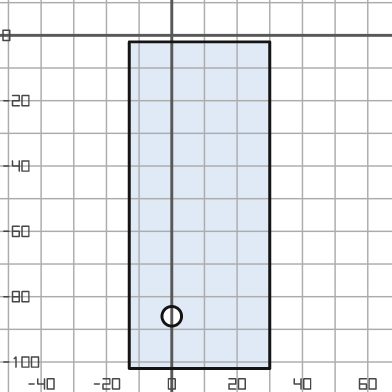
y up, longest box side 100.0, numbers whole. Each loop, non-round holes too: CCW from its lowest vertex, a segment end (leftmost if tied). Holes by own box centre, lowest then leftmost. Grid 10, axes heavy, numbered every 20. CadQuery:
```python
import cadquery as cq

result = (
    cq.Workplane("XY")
    .moveTo(-13.0, -102.0)
    .lineTo(30.0, -102.0)
    .lineTo(30.0, -2.0)
    .lineTo(-13.0, -2.0)
    .close()
    .moveTo(0.0, -86.0)
    .circle(3.0)
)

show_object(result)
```